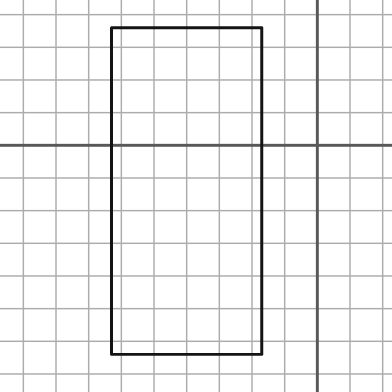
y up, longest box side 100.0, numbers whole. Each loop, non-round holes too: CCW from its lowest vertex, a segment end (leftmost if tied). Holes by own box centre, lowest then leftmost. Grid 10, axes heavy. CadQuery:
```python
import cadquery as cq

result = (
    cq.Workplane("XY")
    .moveTo(-63.0, -64.0)
    .lineTo(-17.0, -64.0)
    .lineTo(-17.0, 36.0)
    .lineTo(-63.0, 36.0)
    .close()
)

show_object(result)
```